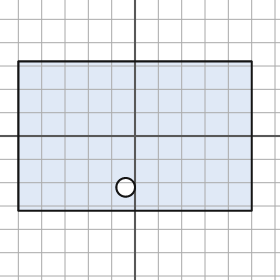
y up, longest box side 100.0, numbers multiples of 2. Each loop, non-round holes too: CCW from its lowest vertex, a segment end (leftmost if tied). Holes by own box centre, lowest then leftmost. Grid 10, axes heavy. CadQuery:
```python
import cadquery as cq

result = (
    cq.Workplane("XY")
    .moveTo(-50.0, -32.0)
    .lineTo(50.0, -32.0)
    .lineTo(50.0, 32.0)
    .lineTo(-50.0, 32.0)
    .close()
    .moveTo(-4.0, -22.0)
    .circle(4.0)
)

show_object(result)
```